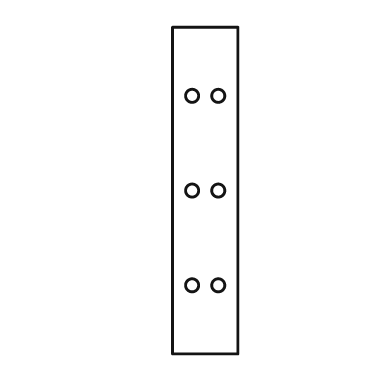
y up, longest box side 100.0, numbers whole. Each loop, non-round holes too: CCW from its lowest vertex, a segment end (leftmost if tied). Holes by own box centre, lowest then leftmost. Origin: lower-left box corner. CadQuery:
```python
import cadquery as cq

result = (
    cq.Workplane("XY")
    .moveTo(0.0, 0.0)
    .lineTo(20.0, 0.0)
    .lineTo(20.0, 100.0)
    .lineTo(0.0, 100.0)
    .close()
    .moveTo(6.0, 21.0)
    .circle(2.0)
    .moveTo(14.0, 21.0)
    .circle(2.0)
    .moveTo(6.0, 50.0)
    .circle(2.0)
    .moveTo(14.0, 50.0)
    .circle(2.0)
    .moveTo(6.0, 79.0)
    .circle(2.0)
    .moveTo(14.0, 79.0)
    .circle(2.0)
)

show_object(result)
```